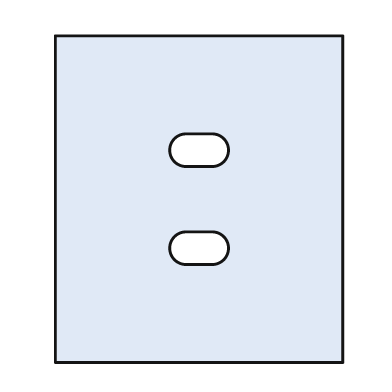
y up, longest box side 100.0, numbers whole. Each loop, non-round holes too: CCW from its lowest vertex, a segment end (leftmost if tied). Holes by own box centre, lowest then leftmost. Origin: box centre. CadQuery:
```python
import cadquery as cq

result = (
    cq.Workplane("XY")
    .moveTo(-44.0, -50.0)
    .lineTo(44.0, -50.0)
    .lineTo(44.0, 50.0)
    .lineTo(-44.0, 50.0)
    .close()
    .moveTo(-4.0, -20.0)
    .lineTo(4.0, -20.0)
    .threePointArc((9.0, -15.0), (4.0, -10.0))
    .lineTo(-4.0, -10.0)
    .threePointArc((-9.0, -15.0), (-4.0, -20.0))
    .close()
    .moveTo(-4.0, 10.0)
    .lineTo(4.0, 10.0)
    .threePointArc((9.0, 15.0), (4.0, 20.0))
    .lineTo(-4.0, 20.0)
    .threePointArc((-9.0, 15.0), (-4.0, 10.0))
    .close()
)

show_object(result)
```